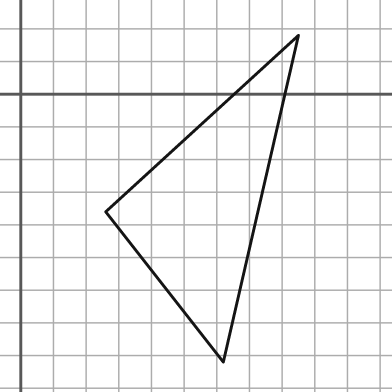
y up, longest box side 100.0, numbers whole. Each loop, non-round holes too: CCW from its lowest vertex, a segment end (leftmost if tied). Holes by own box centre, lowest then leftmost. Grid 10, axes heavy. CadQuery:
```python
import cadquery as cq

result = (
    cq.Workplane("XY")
    .moveTo(62.0, -82.0)
    .lineTo(85.0, 18.0)
    .lineTo(26.0, -36.0)
    .close()
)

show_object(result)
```